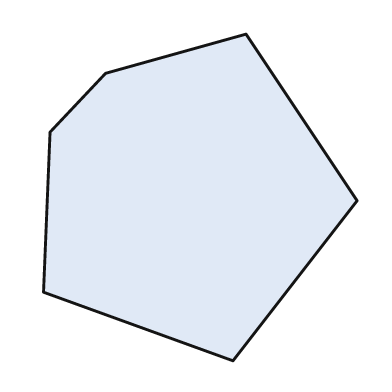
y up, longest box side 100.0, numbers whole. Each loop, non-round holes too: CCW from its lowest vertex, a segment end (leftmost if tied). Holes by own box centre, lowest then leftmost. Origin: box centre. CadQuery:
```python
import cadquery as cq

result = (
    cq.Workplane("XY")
    .moveTo(10.0, -50.0)
    .lineTo(48.0, -1.0)
    .lineTo(14.0, 50.0)
    .lineTo(-29.0, 38.0)
    .lineTo(-46.0, 20.0)
    .lineTo(-48.0, -29.0)
    .close()
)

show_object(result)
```